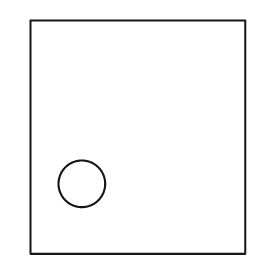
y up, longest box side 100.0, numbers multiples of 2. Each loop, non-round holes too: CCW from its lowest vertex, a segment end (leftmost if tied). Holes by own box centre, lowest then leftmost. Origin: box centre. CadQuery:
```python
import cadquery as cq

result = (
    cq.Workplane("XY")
    .moveTo(-46.0, -50.0)
    .lineTo(46.0, -50.0)
    .lineTo(46.0, 50.0)
    .lineTo(-46.0, 50.0)
    .close()
    .moveTo(-24.0, -20.0)
    .circle(10.0)
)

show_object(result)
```